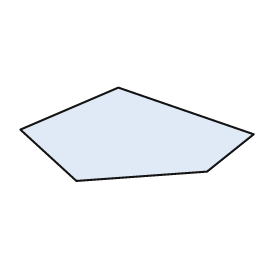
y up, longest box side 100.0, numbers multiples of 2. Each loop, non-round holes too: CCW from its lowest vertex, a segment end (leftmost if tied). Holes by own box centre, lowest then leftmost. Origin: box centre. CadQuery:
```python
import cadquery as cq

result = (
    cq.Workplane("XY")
    .moveTo(-26.0, -20.0)
    .lineTo(30.0, -16.0)
    .lineTo(50.0, 0.0)
    .lineTo(-8.0, 20.0)
    .lineTo(-50.0, 2.0)
    .close()
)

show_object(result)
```